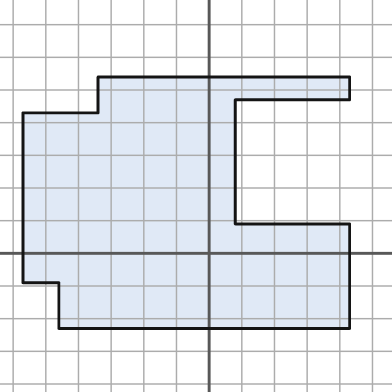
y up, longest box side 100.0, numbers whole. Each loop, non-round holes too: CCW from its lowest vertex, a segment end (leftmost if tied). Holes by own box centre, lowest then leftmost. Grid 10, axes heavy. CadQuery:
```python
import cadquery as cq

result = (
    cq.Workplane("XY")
    .moveTo(-46.0, -23.0)
    .lineTo(43.0, -23.0)
    .lineTo(43.0, 9.0)
    .lineTo(8.0, 9.0)
    .lineTo(8.0, 47.0)
    .lineTo(43.0, 47.0)
    .lineTo(43.0, 54.0)
    .lineTo(-34.0, 54.0)
    .lineTo(-34.0, 43.0)
    .lineTo(-57.0, 43.0)
    .lineTo(-57.0, -9.0)
    .lineTo(-46.0, -9.0)
    .close()
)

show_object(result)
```